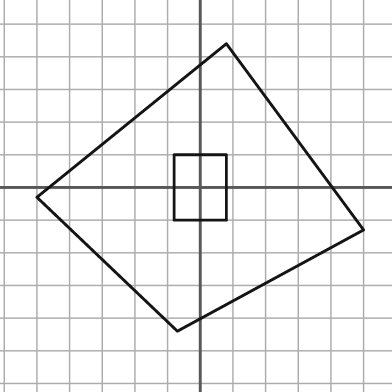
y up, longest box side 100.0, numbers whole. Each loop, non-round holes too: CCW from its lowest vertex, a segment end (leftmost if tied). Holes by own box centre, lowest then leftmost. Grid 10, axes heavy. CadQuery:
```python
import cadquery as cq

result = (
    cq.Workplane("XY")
    .moveTo(-7.0, -44.0)
    .lineTo(50.0, -13.0)
    .lineTo(8.0, 44.0)
    .lineTo(-50.0, -3.0)
    .close()
    .moveTo(-8.0, -10.0)
    .lineTo(8.0, -10.0)
    .lineTo(8.0, 10.0)
    .lineTo(-8.0, 10.0)
    .close()
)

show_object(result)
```